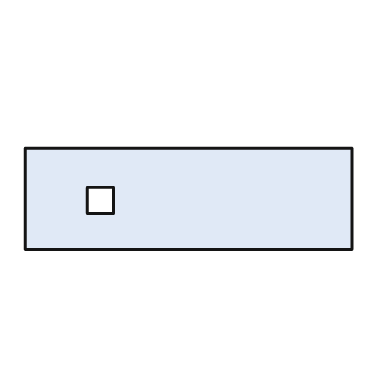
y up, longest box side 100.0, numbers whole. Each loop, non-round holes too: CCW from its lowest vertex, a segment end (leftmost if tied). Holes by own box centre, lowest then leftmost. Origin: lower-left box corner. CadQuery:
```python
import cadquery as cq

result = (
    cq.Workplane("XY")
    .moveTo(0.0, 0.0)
    .lineTo(100.0, 0.0)
    .lineTo(100.0, 31.0)
    .lineTo(0.0, 31.0)
    .close()
    .moveTo(19.0, 11.0)
    .lineTo(27.0, 11.0)
    .lineTo(27.0, 19.0)
    .lineTo(19.0, 19.0)
    .close()
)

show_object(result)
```